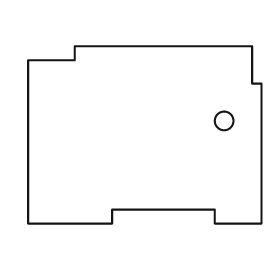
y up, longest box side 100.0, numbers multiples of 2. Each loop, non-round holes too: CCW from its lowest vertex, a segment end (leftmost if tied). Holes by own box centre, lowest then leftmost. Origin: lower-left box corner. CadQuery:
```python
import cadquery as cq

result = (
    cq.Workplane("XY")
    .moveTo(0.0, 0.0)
    .lineTo(36.0, 0.0)
    .lineTo(36.0, 6.0)
    .lineTo(80.0, 6.0)
    .lineTo(80.0, 0.0)
    .lineTo(100.0, 0.0)
    .lineTo(100.0, 60.0)
    .lineTo(96.0, 60.0)
    .lineTo(96.0, 76.0)
    .lineTo(20.0, 76.0)
    .lineTo(20.0, 70.0)
    .lineTo(0.0, 70.0)
    .close()
    .moveTo(84.0, 44.0)
    .circle(4.0)
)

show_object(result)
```